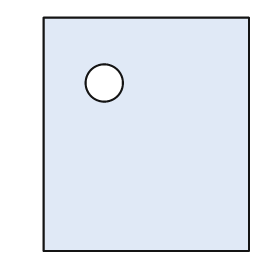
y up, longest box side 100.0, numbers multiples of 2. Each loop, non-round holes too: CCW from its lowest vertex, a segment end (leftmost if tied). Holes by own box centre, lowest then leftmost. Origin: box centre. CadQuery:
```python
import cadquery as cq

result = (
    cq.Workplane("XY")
    .moveTo(-44.0, -50.0)
    .lineTo(44.0, -50.0)
    .lineTo(44.0, 50.0)
    .lineTo(-44.0, 50.0)
    .close()
    .moveTo(-18.0, 22.0)
    .circle(8.0)
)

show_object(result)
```